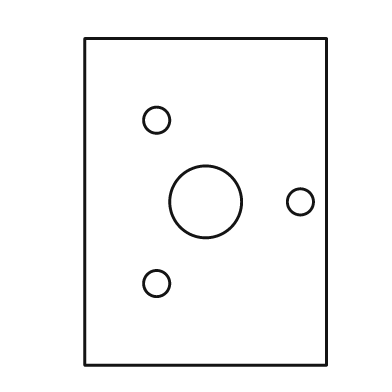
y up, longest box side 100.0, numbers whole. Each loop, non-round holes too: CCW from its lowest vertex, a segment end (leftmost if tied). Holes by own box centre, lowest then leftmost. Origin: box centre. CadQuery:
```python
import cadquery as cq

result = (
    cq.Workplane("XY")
    .moveTo(-37.0, -50.0)
    .lineTo(37.0, -50.0)
    .lineTo(37.0, 50.0)
    .lineTo(-37.0, 50.0)
    .close()
    .moveTo(-15.0, -25.0)
    .circle(4.0)
    .moveTo(0.0, 0.0)
    .circle(11.0)
    .moveTo(29.0, 0.0)
    .circle(4.0)
    .moveTo(-15.0, 25.0)
    .circle(4.0)
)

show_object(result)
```